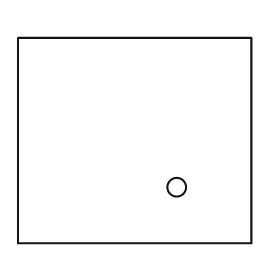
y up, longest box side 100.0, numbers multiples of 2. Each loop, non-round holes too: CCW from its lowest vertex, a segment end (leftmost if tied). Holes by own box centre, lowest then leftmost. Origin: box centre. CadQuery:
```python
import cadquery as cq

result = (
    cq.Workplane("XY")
    .moveTo(-50.0, -44.0)
    .lineTo(50.0, -44.0)
    .lineTo(50.0, 44.0)
    .lineTo(-50.0, 44.0)
    .close()
    .moveTo(18.0, -20.0)
    .circle(4.0)
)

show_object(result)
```